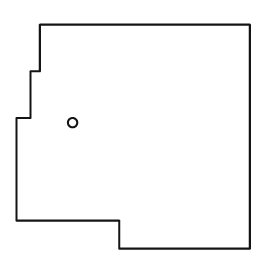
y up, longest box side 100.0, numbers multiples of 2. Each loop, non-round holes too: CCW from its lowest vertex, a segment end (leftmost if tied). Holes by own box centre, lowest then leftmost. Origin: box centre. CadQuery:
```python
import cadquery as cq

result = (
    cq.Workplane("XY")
    .moveTo(-6.0, -48.0)
    .lineTo(50.0, -48.0)
    .lineTo(50.0, 48.0)
    .lineTo(-40.0, 48.0)
    .lineTo(-40.0, 28.0)
    .lineTo(-44.0, 28.0)
    .lineTo(-44.0, 8.0)
    .lineTo(-50.0, 8.0)
    .lineTo(-50.0, -36.0)
    .lineTo(-6.0, -36.0)
    .close()
    .moveTo(-26.0, 6.0)
    .circle(2.0)
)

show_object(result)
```